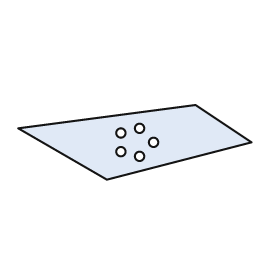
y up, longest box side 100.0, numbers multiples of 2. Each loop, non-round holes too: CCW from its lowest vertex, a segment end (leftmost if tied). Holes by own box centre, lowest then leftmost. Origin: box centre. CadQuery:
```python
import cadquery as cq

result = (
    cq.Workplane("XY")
    .moveTo(-12.0, -16.0)
    .lineTo(50.0, 0.0)
    .lineTo(26.0, 16.0)
    .lineTo(-50.0, 6.0)
    .close()
    .moveTo(2.0, -6.0)
    .circle(2.0)
    .moveTo(-6.0, -4.0)
    .circle(2.0)
    .moveTo(8.0, 0.0)
    .circle(2.0)
    .moveTo(-6.0, 4.0)
    .circle(2.0)
    .moveTo(2.0, 6.0)
    .circle(2.0)
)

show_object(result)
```